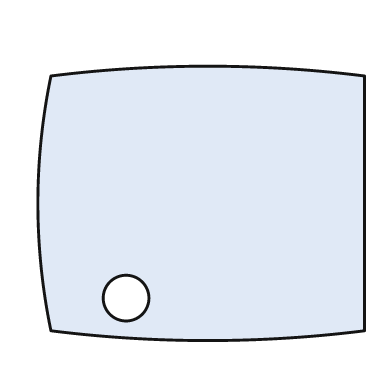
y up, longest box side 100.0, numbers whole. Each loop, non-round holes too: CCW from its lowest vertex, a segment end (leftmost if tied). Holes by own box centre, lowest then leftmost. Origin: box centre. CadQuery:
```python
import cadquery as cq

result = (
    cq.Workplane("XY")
    .moveTo(-46.0, -39.0)
    .threePointArc((2.0, -42.0), (50.0, -39.0))
    .lineTo(50.0, 39.0)
    .threePointArc((2.0, 42.0), (-46.0, 39.0))
    .threePointArc((-50.0, 0.0), (-46.0, -39.0))
    .close()
    .moveTo(-23.0, -29.0)
    .circle(7.0)
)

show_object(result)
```